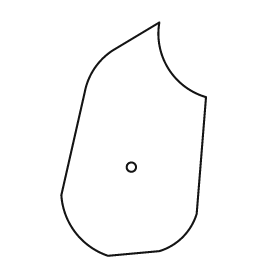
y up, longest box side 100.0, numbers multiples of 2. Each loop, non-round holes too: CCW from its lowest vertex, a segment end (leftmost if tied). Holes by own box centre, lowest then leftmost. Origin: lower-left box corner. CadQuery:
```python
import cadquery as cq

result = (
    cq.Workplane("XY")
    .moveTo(20.0, 0.0)
    .lineTo(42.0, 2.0)
    .threePointArc((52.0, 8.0), (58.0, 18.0))
    .lineTo(62.0, 68.0)
    .threePointArc((46.0, 80.0), (42.0, 100.0))
    .lineTo(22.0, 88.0)
    .threePointArc((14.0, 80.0), (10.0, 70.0))
    .lineTo(0.0, 26.0)
    .threePointArc((6.0, 10.0), (20.0, 0.0))
    .close()
    .moveTo(30.0, 38.0)
    .circle(2.0)
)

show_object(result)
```